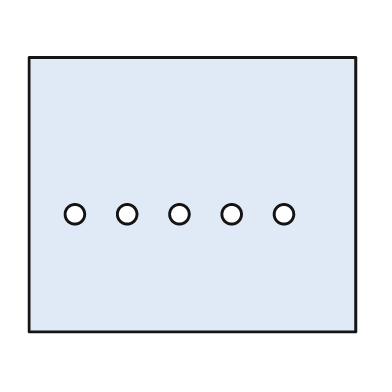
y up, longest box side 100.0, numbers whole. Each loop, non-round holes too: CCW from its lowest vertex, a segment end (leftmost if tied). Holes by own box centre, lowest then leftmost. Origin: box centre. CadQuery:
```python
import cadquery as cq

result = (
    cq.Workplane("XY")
    .moveTo(-50.0, -42.0)
    .lineTo(50.0, -42.0)
    .lineTo(50.0, 42.0)
    .lineTo(-50.0, 42.0)
    .close()
    .moveTo(-36.0, -6.0)
    .circle(3.0)
    .moveTo(-20.0, -6.0)
    .circle(3.0)
    .moveTo(-4.0, -6.0)
    .circle(3.0)
    .moveTo(12.0, -6.0)
    .circle(3.0)
    .moveTo(28.0, -6.0)
    .circle(3.0)
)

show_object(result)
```